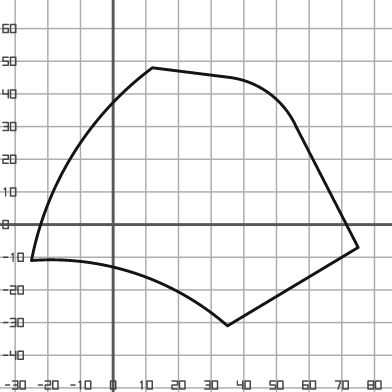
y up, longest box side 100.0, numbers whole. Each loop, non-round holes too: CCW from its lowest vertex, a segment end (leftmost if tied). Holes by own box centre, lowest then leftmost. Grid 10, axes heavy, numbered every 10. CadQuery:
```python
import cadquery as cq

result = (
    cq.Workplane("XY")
    .moveTo(35.0, -31.0)
    .lineTo(75.0, -7.0)
    .lineTo(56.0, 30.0)
    .threePointArc((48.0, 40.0), (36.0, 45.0))
    .lineTo(12.0, 48.0)
    .threePointArc((-12.0, 22.0), (-25.0, -11.0))
    .threePointArc((7.0, -15.0), (35.0, -31.0))
    .close()
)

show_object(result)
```